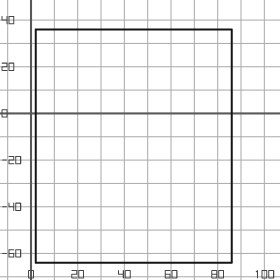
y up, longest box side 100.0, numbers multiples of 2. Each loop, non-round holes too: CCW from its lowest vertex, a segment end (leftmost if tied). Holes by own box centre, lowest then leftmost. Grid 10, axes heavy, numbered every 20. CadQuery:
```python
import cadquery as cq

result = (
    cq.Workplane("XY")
    .moveTo(2.0, -64.0)
    .lineTo(86.0, -64.0)
    .lineTo(86.0, 36.0)
    .lineTo(2.0, 36.0)
    .close()
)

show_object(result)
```